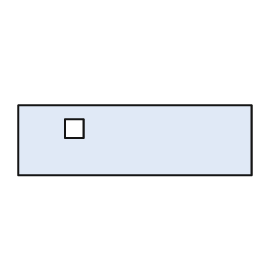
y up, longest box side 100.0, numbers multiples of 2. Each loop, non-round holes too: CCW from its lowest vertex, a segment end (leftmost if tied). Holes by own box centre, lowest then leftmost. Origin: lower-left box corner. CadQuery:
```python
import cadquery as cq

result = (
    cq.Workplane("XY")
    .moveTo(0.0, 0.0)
    .lineTo(100.0, 0.0)
    .lineTo(100.0, 30.0)
    .lineTo(0.0, 30.0)
    .close()
    .moveTo(20.0, 16.0)
    .lineTo(28.0, 16.0)
    .lineTo(28.0, 24.0)
    .lineTo(20.0, 24.0)
    .close()
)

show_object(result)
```